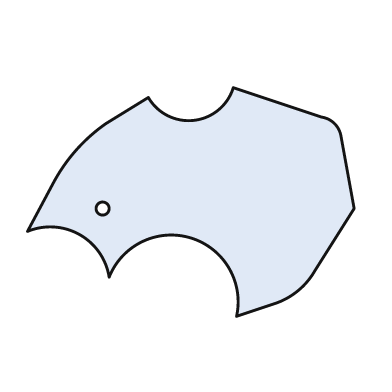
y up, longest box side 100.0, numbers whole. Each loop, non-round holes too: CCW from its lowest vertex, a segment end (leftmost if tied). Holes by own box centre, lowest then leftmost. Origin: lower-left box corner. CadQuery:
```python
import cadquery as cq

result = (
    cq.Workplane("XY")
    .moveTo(64.0, 0.0)
    .lineTo(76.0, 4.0)
    .threePointArc((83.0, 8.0), (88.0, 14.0))
    .lineTo(100.0, 33.0)
    .lineTo(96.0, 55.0)
    .threePointArc((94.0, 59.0), (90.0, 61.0))
    .lineTo(63.0, 70.0)
    .threePointArc((51.0, 60.0), (37.0, 67.0))
    .lineTo(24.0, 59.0)
    .threePointArc((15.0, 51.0), (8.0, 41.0))
    .lineTo(0.0, 26.0)
    .threePointArc((16.0, 25.0), (25.0, 12.0))
    .threePointArc((50.0, 24.0), (64.0, 0.0))
    .close()
    .moveTo(23.0, 33.0)
    .circle(2.0)
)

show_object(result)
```